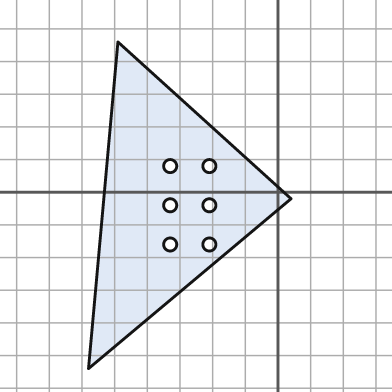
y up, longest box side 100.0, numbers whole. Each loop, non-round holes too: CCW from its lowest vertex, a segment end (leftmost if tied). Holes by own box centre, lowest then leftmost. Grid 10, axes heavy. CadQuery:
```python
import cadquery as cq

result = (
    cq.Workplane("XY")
    .moveTo(-58.0, -54.0)
    .lineTo(4.0, -2.0)
    .lineTo(-49.0, 46.0)
    .close()
    .moveTo(-33.0, -16.0)
    .circle(2.0)
    .moveTo(-21.0, -16.0)
    .circle(2.0)
    .moveTo(-33.0, -4.0)
    .circle(2.0)
    .moveTo(-21.0, -4.0)
    .circle(2.0)
    .moveTo(-33.0, 8.0)
    .circle(2.0)
    .moveTo(-21.0, 8.0)
    .circle(2.0)
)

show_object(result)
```